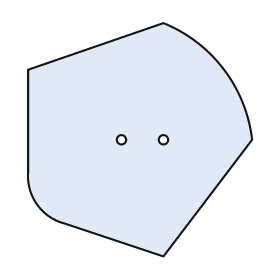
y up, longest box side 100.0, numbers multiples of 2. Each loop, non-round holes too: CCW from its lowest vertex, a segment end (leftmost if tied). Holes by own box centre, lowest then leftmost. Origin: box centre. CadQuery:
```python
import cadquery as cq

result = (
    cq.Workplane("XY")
    .moveTo(10.0, -50.0)
    .lineTo(48.0, 0.0)
    .threePointArc((36.0, 30.0), (10.0, 50.0))
    .lineTo(-48.0, 30.0)
    .lineTo(-48.0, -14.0)
    .threePointArc((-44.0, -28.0), (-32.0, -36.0))
    .close()
    .moveTo(-8.0, 0.0)
    .circle(2.0)
    .moveTo(10.0, 0.0)
    .circle(2.0)
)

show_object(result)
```